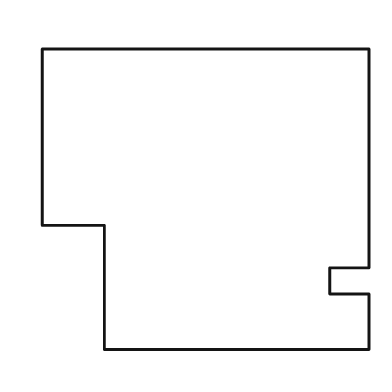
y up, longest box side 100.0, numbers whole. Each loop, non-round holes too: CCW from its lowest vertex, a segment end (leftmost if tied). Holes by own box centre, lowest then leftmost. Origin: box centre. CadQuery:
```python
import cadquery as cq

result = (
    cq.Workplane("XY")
    .moveTo(-31.0, -46.0)
    .lineTo(50.0, -46.0)
    .lineTo(50.0, -29.0)
    .lineTo(38.0, -29.0)
    .lineTo(38.0, -21.0)
    .lineTo(50.0, -21.0)
    .lineTo(50.0, 46.0)
    .lineTo(-50.0, 46.0)
    .lineTo(-50.0, -8.0)
    .lineTo(-31.0, -8.0)
    .close()
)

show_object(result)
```